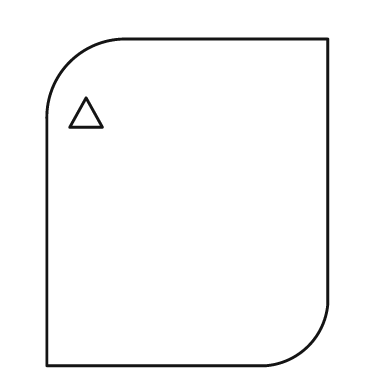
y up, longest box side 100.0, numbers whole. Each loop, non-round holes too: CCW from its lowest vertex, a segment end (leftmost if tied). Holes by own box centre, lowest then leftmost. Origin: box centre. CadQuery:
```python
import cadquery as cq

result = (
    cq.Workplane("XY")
    .moveTo(-43.0, -50.0)
    .lineTo(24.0, -50.0)
    .threePointArc((37.0, -44.0), (43.0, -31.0))
    .lineTo(43.0, 50.0)
    .lineTo(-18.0, 50.0)
    .threePointArc((-36.0, 43.0), (-43.0, 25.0))
    .close()
    .moveTo(-36.0, 23.0)
    .lineTo(-26.0, 23.0)
    .lineTo(-31.0, 32.0)
    .close()
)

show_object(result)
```